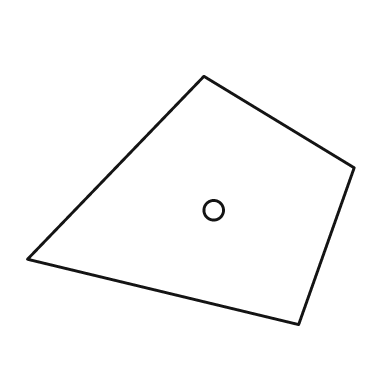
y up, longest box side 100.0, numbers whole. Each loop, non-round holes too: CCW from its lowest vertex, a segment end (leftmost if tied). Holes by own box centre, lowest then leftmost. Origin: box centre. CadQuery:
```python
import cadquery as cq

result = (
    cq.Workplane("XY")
    .moveTo(33.0, -38.0)
    .lineTo(50.0, 10.0)
    .lineTo(4.0, 38.0)
    .lineTo(-50.0, -18.0)
    .close()
    .moveTo(7.0, -3.0)
    .circle(3.0)
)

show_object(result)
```